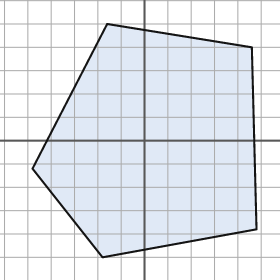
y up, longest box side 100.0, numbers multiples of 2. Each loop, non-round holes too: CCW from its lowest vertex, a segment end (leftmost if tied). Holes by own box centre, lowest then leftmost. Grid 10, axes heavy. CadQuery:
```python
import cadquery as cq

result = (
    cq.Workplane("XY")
    .moveTo(-18.0, -50.0)
    .lineTo(48.0, -38.0)
    .lineTo(46.0, 40.0)
    .lineTo(-16.0, 50.0)
    .lineTo(-48.0, -12.0)
    .close()
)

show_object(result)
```